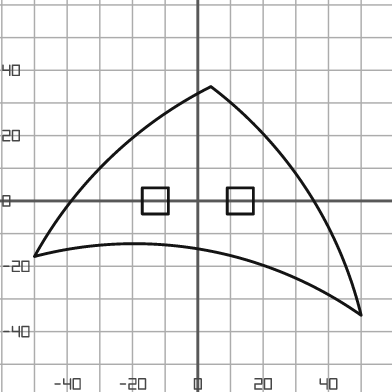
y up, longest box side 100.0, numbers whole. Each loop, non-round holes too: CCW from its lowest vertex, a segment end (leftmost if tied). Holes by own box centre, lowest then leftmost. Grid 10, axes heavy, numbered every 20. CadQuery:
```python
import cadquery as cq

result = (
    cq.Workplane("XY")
    .moveTo(50.0, -35.0)
    .threePointArc((33.0, 4.0), (4.0, 35.0))
    .threePointArc((-27.0, 13.0), (-50.0, -17.0))
    .threePointArc((2.0, -15.0), (50.0, -35.0))
    .close()
    .moveTo(-17.0, -4.0)
    .lineTo(-9.0, -4.0)
    .lineTo(-9.0, 4.0)
    .lineTo(-17.0, 4.0)
    .close()
    .moveTo(9.0, -4.0)
    .lineTo(17.0, -4.0)
    .lineTo(17.0, 4.0)
    .lineTo(9.0, 4.0)
    .close()
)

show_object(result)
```